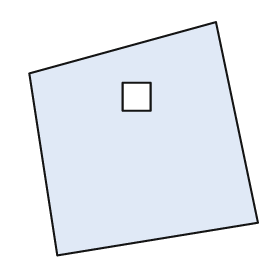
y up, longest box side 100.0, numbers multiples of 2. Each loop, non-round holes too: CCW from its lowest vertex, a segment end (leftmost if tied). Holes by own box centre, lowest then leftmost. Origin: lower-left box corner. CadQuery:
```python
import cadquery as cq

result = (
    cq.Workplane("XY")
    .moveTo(12.0, 0.0)
    .lineTo(98.0, 14.0)
    .lineTo(80.0, 100.0)
    .lineTo(0.0, 78.0)
    .close()
    .moveTo(40.0, 62.0)
    .lineTo(52.0, 62.0)
    .lineTo(52.0, 74.0)
    .lineTo(40.0, 74.0)
    .close()
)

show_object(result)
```